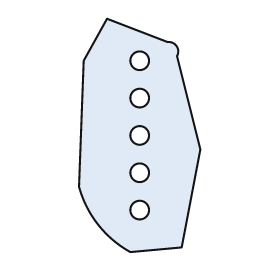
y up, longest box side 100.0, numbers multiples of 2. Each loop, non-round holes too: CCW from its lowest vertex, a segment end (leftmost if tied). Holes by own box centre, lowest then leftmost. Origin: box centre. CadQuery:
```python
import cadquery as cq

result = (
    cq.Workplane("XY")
    .moveTo(-4.0, -50.0)
    .lineTo(18.0, -48.0)
    .lineTo(26.0, -6.0)
    .lineTo(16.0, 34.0)
    .threePointArc((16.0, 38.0), (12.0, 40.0))
    .lineTo(-14.0, 50.0)
    .lineTo(-24.0, 32.0)
    .lineTo(-26.0, -22.0)
    .threePointArc((-18.0, -38.0), (-4.0, -50.0))
    .close()
    .moveTo(0.0, -32.0)
    .circle(4.0)
    .moveTo(0.0, -16.0)
    .circle(4.0)
    .moveTo(0.0, 0.0)
    .circle(4.0)
    .moveTo(0.0, 16.0)
    .circle(4.0)
    .moveTo(0.0, 32.0)
    .circle(4.0)
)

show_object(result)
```